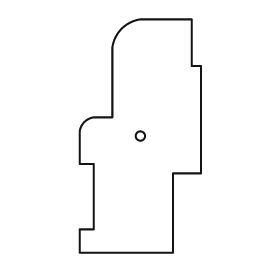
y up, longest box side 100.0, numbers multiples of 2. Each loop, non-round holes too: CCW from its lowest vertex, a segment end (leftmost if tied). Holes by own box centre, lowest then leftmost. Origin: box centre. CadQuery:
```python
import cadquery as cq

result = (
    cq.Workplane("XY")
    .moveTo(-26.0, -50.0)
    .lineTo(14.0, -50.0)
    .lineTo(14.0, -16.0)
    .lineTo(26.0, -16.0)
    .lineTo(26.0, 30.0)
    .lineTo(22.0, 30.0)
    .lineTo(22.0, 50.0)
    .lineTo(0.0, 50.0)
    .threePointArc((-8.0, 46.0), (-12.0, 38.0))
    .lineTo(-12.0, 8.0)
    .lineTo(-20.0, 8.0)
    .threePointArc((-24.0, 6.0), (-26.0, 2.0))
    .lineTo(-26.0, -12.0)
    .lineTo(-20.0, -12.0)
    .lineTo(-20.0, -40.0)
    .lineTo(-26.0, -40.0)
    .close()
    .moveTo(0.0, 0.0)
    .circle(2.0)
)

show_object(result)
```